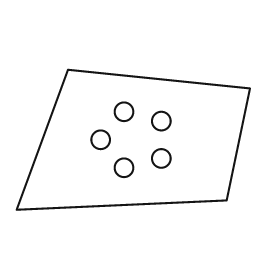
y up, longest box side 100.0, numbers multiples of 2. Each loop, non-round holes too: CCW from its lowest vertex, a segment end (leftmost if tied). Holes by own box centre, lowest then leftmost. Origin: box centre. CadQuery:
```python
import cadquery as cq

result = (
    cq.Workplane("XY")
    .moveTo(-50.0, -30.0)
    .lineTo(40.0, -26.0)
    .lineTo(50.0, 22.0)
    .lineTo(-28.0, 30.0)
    .close()
    .moveTo(-4.0, -12.0)
    .circle(4.0)
    .moveTo(12.0, -8.0)
    .circle(4.0)
    .moveTo(-14.0, 0.0)
    .circle(4.0)
    .moveTo(12.0, 8.0)
    .circle(4.0)
    .moveTo(-4.0, 12.0)
    .circle(4.0)
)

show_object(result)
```